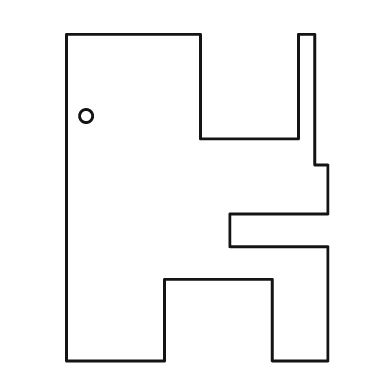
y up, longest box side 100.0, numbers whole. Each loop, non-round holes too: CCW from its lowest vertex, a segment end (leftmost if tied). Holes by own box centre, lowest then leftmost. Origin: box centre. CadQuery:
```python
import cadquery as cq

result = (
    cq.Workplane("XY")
    .moveTo(-40.0, -50.0)
    .lineTo(-10.0, -50.0)
    .lineTo(-10.0, -25.0)
    .lineTo(23.0, -25.0)
    .lineTo(23.0, -50.0)
    .lineTo(40.0, -50.0)
    .lineTo(40.0, -15.0)
    .lineTo(10.0, -15.0)
    .lineTo(10.0, -5.0)
    .lineTo(40.0, -5.0)
    .lineTo(40.0, 10.0)
    .lineTo(36.0, 10.0)
    .lineTo(36.0, 50.0)
    .lineTo(31.0, 50.0)
    .lineTo(31.0, 18.0)
    .lineTo(1.0, 18.0)
    .lineTo(1.0, 50.0)
    .lineTo(-40.0, 50.0)
    .close()
    .moveTo(-34.0, 25.0)
    .circle(2.0)
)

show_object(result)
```